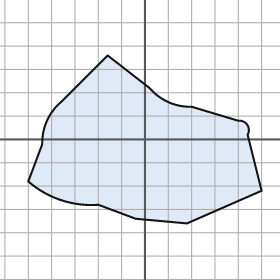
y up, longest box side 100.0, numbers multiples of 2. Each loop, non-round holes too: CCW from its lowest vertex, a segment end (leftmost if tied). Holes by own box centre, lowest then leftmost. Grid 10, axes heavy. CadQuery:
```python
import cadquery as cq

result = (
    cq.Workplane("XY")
    .moveTo(18.0, -36.0)
    .lineTo(50.0, -22.0)
    .lineTo(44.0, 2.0)
    .threePointArc((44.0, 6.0), (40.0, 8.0))
    .lineTo(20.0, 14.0)
    .threePointArc((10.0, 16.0), (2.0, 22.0))
    .lineTo(-16.0, 36.0)
    .lineTo(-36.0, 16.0)
    .threePointArc((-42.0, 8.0), (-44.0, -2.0))
    .lineTo(-50.0, -18.0)
    .threePointArc((-36.0, -26.0), (-20.0, -28.0))
    .lineTo(-4.0, -34.0)
    .close()
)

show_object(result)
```